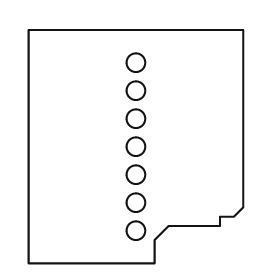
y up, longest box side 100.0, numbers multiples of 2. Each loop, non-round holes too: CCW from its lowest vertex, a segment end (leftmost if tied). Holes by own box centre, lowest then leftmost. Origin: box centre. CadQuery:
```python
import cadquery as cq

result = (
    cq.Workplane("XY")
    .moveTo(-46.0, -50.0)
    .lineTo(8.0, -50.0)
    .lineTo(8.0, -40.0)
    .lineTo(14.0, -34.0)
    .lineTo(36.0, -34.0)
    .lineTo(36.0, -30.0)
    .lineTo(42.0, -30.0)
    .lineTo(46.0, -26.0)
    .lineTo(46.0, 50.0)
    .lineTo(-46.0, 50.0)
    .close()
    .moveTo(0.0, -36.0)
    .circle(4.0)
    .moveTo(0.0, -24.0)
    .circle(4.0)
    .moveTo(0.0, -12.0)
    .circle(4.0)
    .moveTo(0.0, 0.0)
    .circle(4.0)
    .moveTo(0.0, 12.0)
    .circle(4.0)
    .moveTo(0.0, 24.0)
    .circle(4.0)
    .moveTo(0.0, 36.0)
    .circle(4.0)
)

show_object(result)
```